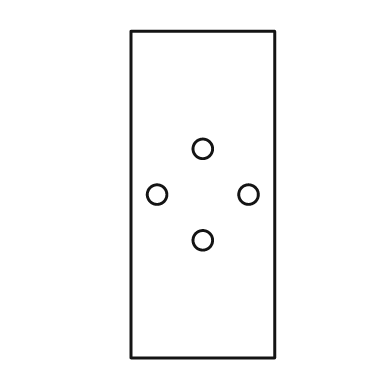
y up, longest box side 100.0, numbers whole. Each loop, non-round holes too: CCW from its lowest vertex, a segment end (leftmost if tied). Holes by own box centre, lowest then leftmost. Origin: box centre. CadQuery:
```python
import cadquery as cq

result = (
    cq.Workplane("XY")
    .moveTo(-22.0, -50.0)
    .lineTo(22.0, -50.0)
    .lineTo(22.0, 50.0)
    .lineTo(-22.0, 50.0)
    .close()
    .moveTo(0.0, -14.0)
    .circle(3.0)
    .moveTo(-14.0, 0.0)
    .circle(3.0)
    .moveTo(14.0, 0.0)
    .circle(3.0)
    .moveTo(0.0, 14.0)
    .circle(3.0)
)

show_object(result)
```